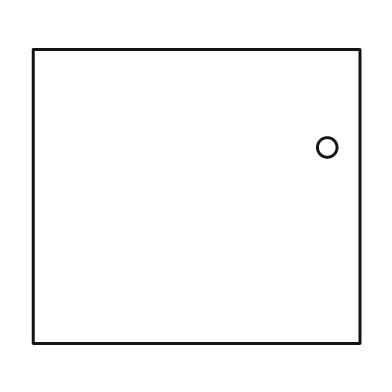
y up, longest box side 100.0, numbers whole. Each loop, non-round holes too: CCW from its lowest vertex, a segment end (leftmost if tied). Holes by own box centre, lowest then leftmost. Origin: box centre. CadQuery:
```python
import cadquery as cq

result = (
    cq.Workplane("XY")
    .moveTo(-50.0, -45.0)
    .lineTo(50.0, -45.0)
    .lineTo(50.0, 45.0)
    .lineTo(-50.0, 45.0)
    .close()
    .moveTo(40.0, 15.0)
    .circle(3.0)
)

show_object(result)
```